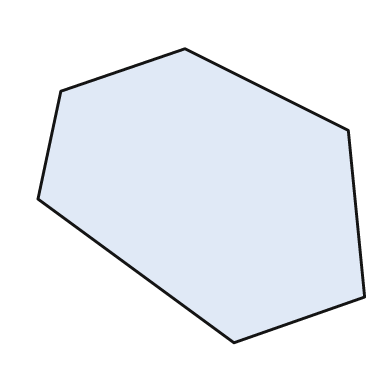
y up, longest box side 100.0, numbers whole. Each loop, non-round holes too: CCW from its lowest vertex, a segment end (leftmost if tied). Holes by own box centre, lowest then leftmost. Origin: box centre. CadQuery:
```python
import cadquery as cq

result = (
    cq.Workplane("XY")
    .moveTo(10.0, -45.0)
    .lineTo(50.0, -31.0)
    .lineTo(45.0, 20.0)
    .lineTo(-5.0, 45.0)
    .lineTo(-43.0, 32.0)
    .lineTo(-50.0, -1.0)
    .close()
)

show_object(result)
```